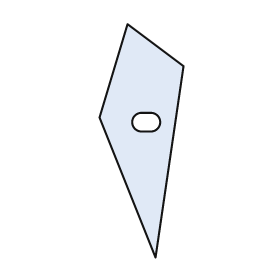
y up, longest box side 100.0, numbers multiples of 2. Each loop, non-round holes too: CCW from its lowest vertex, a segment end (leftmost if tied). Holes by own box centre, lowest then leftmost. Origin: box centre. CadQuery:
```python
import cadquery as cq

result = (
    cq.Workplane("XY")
    .moveTo(6.0, -50.0)
    .lineTo(18.0, 32.0)
    .lineTo(-6.0, 50.0)
    .lineTo(-18.0, 10.0)
    .close()
    .moveTo(0.0, 4.0)
    .lineTo(4.0, 4.0)
    .threePointArc((8.0, 8.0), (4.0, 12.0))
    .lineTo(0.0, 12.0)
    .threePointArc((-4.0, 8.0), (0.0, 4.0))
    .close()
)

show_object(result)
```